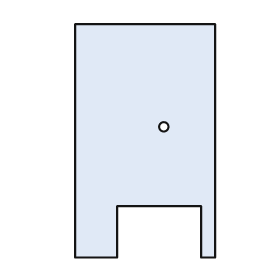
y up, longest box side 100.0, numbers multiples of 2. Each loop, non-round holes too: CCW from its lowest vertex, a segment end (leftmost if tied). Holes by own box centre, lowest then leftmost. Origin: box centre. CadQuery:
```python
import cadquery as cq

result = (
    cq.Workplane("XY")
    .moveTo(-30.0, -50.0)
    .lineTo(-12.0, -50.0)
    .lineTo(-12.0, -28.0)
    .lineTo(24.0, -28.0)
    .lineTo(24.0, -50.0)
    .lineTo(30.0, -50.0)
    .lineTo(30.0, 50.0)
    .lineTo(-30.0, 50.0)
    .close()
    .moveTo(8.0, 6.0)
    .circle(2.0)
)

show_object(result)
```